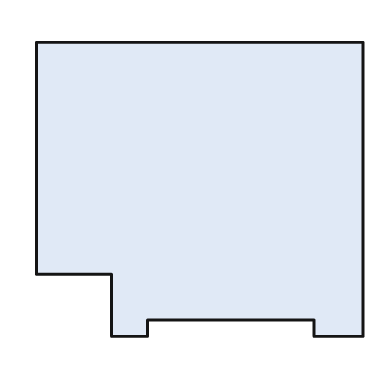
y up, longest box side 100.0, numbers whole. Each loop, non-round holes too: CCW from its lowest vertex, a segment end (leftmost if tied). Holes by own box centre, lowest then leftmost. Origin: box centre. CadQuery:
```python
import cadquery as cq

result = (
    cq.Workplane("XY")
    .moveTo(-27.0, -45.0)
    .lineTo(-16.0, -45.0)
    .lineTo(-16.0, -40.0)
    .lineTo(35.0, -40.0)
    .lineTo(35.0, -45.0)
    .lineTo(50.0, -45.0)
    .lineTo(50.0, 45.0)
    .lineTo(-50.0, 45.0)
    .lineTo(-50.0, -26.0)
    .lineTo(-27.0, -26.0)
    .close()
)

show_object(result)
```